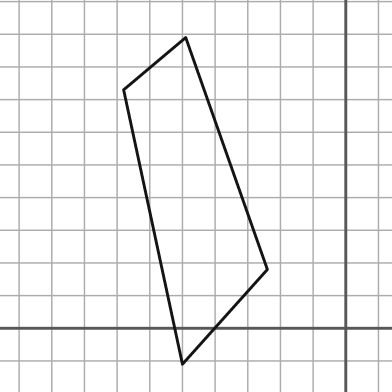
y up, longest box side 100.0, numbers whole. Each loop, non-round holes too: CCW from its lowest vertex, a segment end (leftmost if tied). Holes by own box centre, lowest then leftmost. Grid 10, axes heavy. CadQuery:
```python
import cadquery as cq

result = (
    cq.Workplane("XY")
    .moveTo(-50.0, -11.0)
    .lineTo(-24.0, 18.0)
    .lineTo(-49.0, 89.0)
    .lineTo(-68.0, 73.0)
    .close()
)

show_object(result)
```